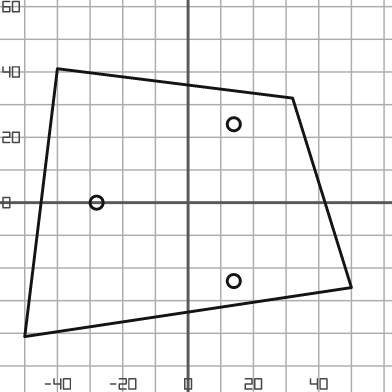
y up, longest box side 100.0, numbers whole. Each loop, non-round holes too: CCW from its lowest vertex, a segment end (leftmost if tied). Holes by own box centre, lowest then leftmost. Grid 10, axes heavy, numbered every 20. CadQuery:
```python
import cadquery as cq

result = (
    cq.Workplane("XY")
    .moveTo(-50.0, -41.0)
    .lineTo(50.0, -26.0)
    .lineTo(32.0, 32.0)
    .lineTo(-40.0, 41.0)
    .close()
    .moveTo(14.0, -24.0)
    .circle(2.0)
    .moveTo(-28.0, 0.0)
    .circle(2.0)
    .moveTo(14.0, 24.0)
    .circle(2.0)
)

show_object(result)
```